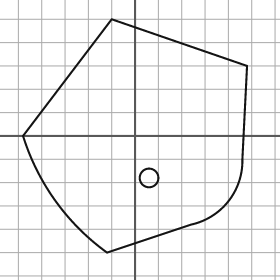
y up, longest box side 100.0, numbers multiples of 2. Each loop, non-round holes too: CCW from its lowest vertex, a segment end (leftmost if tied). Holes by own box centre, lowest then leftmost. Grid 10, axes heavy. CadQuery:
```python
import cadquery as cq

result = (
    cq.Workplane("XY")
    .moveTo(-12.0, -50.0)
    .lineTo(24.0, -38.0)
    .threePointArc((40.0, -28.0), (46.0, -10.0))
    .lineTo(48.0, 30.0)
    .lineTo(-10.0, 50.0)
    .lineTo(-48.0, 0.0)
    .threePointArc((-34.0, -28.0), (-12.0, -50.0))
    .close()
    .moveTo(6.0, -18.0)
    .circle(4.0)
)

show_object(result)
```